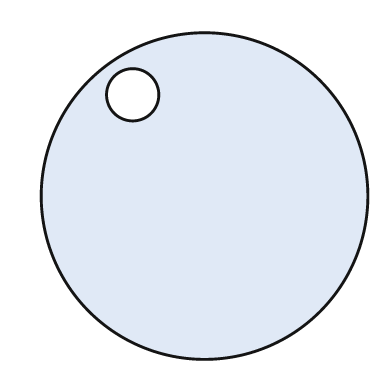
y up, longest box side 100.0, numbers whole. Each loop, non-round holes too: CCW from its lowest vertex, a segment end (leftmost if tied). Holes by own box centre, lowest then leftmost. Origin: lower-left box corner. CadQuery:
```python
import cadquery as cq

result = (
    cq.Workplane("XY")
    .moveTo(50.0, 50.0)
    .circle(50.0)
    .moveTo(28.0, 81.0)
    .circle(8.0)
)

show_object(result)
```